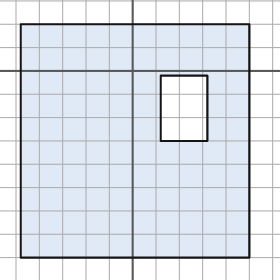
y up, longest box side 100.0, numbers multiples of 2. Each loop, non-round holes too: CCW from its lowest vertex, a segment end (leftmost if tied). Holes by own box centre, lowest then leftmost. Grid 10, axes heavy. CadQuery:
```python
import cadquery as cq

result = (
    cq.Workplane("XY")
    .moveTo(-48.0, -80.0)
    .lineTo(50.0, -80.0)
    .lineTo(50.0, 20.0)
    .lineTo(-48.0, 20.0)
    .close()
    .moveTo(12.0, -30.0)
    .lineTo(32.0, -30.0)
    .lineTo(32.0, -2.0)
    .lineTo(12.0, -2.0)
    .close()
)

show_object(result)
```